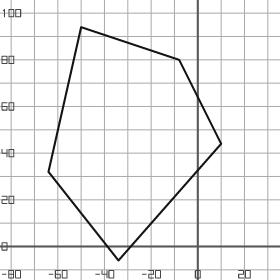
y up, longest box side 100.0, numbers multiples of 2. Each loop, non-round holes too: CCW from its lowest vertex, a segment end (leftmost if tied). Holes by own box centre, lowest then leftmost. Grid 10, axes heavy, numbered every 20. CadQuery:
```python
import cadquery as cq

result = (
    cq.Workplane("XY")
    .moveTo(-34.0, -6.0)
    .lineTo(10.0, 44.0)
    .lineTo(-8.0, 80.0)
    .lineTo(-50.0, 94.0)
    .lineTo(-64.0, 32.0)
    .close()
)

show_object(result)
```